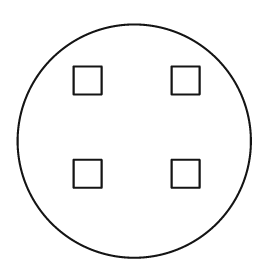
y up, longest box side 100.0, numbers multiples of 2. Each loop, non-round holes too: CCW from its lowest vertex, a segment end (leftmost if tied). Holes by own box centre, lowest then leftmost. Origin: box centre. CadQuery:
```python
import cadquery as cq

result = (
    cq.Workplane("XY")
    .moveTo(0.0, 0.0)
    .circle(50.0)
    .moveTo(-26.0, -20.0)
    .lineTo(-14.0, -20.0)
    .lineTo(-14.0, -8.0)
    .lineTo(-26.0, -8.0)
    .close()
    .moveTo(16.0, -20.0)
    .lineTo(28.0, -20.0)
    .lineTo(28.0, -8.0)
    .lineTo(16.0, -8.0)
    .close()
    .moveTo(-26.0, 20.0)
    .lineTo(-14.0, 20.0)
    .lineTo(-14.0, 32.0)
    .lineTo(-26.0, 32.0)
    .close()
    .moveTo(16.0, 20.0)
    .lineTo(28.0, 20.0)
    .lineTo(28.0, 32.0)
    .lineTo(16.0, 32.0)
    .close()
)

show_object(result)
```